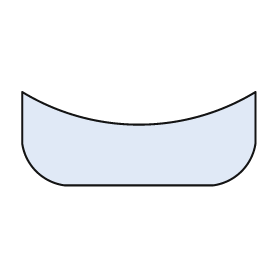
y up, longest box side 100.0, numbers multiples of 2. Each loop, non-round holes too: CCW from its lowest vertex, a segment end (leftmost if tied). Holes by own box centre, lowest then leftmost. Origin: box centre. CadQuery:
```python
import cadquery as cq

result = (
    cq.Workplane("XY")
    .moveTo(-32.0, -20.0)
    .lineTo(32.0, -20.0)
    .threePointArc((44.0, -14.0), (50.0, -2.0))
    .lineTo(50.0, 20.0)
    .threePointArc((0.0, 6.0), (-50.0, 20.0))
    .lineTo(-50.0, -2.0)
    .threePointArc((-44.0, -14.0), (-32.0, -20.0))
    .close()
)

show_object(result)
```